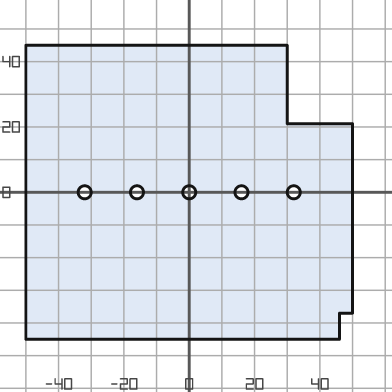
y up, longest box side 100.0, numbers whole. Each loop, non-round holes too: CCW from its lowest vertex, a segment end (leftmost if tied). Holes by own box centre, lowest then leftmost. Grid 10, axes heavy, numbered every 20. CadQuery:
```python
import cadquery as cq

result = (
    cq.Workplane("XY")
    .moveTo(-50.0, -45.0)
    .lineTo(46.0, -45.0)
    .lineTo(46.0, -37.0)
    .lineTo(50.0, -37.0)
    .lineTo(50.0, 21.0)
    .lineTo(30.0, 21.0)
    .lineTo(30.0, 45.0)
    .lineTo(-50.0, 45.0)
    .close()
    .moveTo(-32.0, 0.0)
    .circle(2.0)
    .moveTo(-16.0, 0.0)
    .circle(2.0)
    .moveTo(0.0, 0.0)
    .circle(2.0)
    .moveTo(16.0, 0.0)
    .circle(2.0)
    .moveTo(32.0, 0.0)
    .circle(2.0)
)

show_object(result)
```